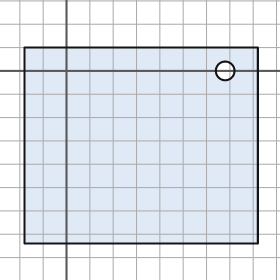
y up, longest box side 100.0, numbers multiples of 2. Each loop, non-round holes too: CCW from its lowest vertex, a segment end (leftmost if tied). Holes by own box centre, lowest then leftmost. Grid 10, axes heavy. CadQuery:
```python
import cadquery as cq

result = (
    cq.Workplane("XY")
    .moveTo(-18.0, -74.0)
    .lineTo(82.0, -74.0)
    .lineTo(82.0, 10.0)
    .lineTo(-18.0, 10.0)
    .close()
    .moveTo(68.0, 0.0)
    .circle(4.0)
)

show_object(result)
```